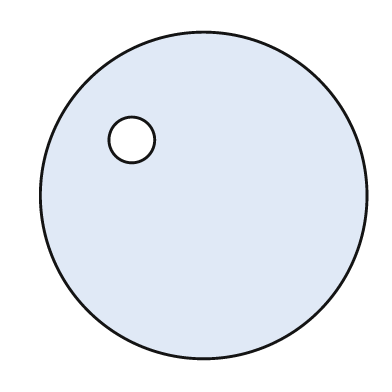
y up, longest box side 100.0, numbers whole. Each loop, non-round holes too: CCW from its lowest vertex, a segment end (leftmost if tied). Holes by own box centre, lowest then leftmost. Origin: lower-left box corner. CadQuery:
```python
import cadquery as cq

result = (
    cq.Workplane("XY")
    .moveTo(50.0, 50.0)
    .circle(50.0)
    .moveTo(28.0, 67.0)
    .circle(7.0)
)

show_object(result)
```